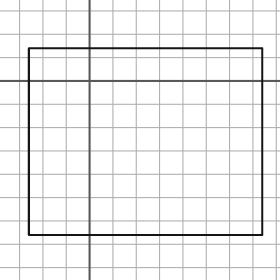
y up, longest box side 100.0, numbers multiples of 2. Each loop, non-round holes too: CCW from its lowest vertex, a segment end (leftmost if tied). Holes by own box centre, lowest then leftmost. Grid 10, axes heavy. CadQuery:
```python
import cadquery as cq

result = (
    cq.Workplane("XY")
    .moveTo(-26.0, -66.0)
    .lineTo(74.0, -66.0)
    .lineTo(74.0, 14.0)
    .lineTo(-26.0, 14.0)
    .close()
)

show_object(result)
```